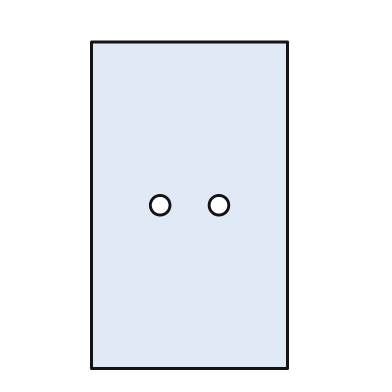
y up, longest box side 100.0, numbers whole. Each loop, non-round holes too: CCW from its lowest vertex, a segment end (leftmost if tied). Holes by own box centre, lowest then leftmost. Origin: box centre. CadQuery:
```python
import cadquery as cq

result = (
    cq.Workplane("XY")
    .moveTo(-30.0, -50.0)
    .lineTo(30.0, -50.0)
    .lineTo(30.0, 50.0)
    .lineTo(-30.0, 50.0)
    .close()
    .moveTo(-9.0, 0.0)
    .circle(3.0)
    .moveTo(9.0, 0.0)
    .circle(3.0)
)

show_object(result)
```